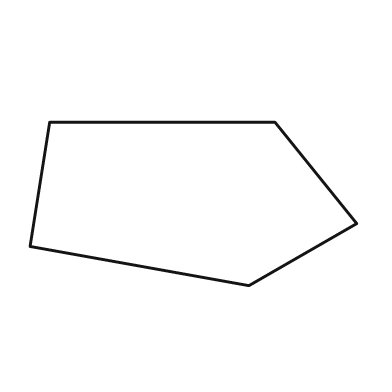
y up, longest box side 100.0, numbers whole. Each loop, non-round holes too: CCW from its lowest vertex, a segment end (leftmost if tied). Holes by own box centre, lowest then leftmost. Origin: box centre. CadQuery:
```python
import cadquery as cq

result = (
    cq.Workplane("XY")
    .moveTo(17.0, -25.0)
    .lineTo(50.0, -6.0)
    .lineTo(25.0, 25.0)
    .lineTo(-44.0, 25.0)
    .lineTo(-50.0, -13.0)
    .close()
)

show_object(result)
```